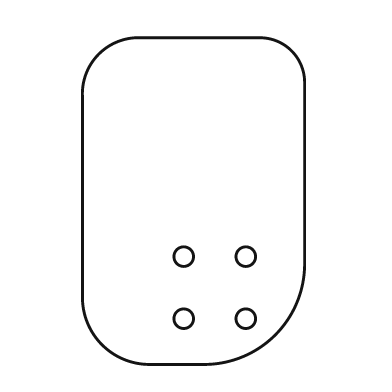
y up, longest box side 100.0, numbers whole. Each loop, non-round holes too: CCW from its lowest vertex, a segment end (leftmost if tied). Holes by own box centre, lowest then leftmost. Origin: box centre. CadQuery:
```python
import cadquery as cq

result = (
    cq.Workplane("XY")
    .moveTo(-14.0, -50.0)
    .lineTo(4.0, -50.0)
    .threePointArc((25.0, -41.0), (34.0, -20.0))
    .lineTo(34.0, 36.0)
    .threePointArc((30.0, 46.0), (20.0, 50.0))
    .lineTo(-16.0, 50.0)
    .threePointArc((-29.0, 45.0), (-34.0, 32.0))
    .lineTo(-34.0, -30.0)
    .threePointArc((-28.0, -44.0), (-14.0, -50.0))
    .close()
    .moveTo(-3.0, -36.0)
    .circle(3.0)
    .moveTo(16.0, -36.0)
    .circle(3.0)
    .moveTo(-3.0, -17.0)
    .circle(3.0)
    .moveTo(16.0, -17.0)
    .circle(3.0)
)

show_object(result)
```